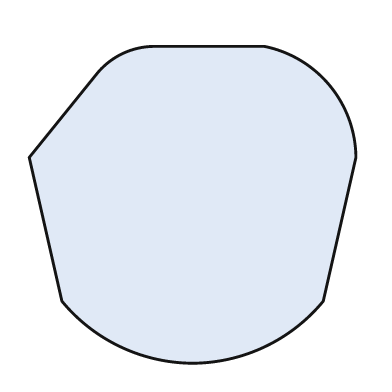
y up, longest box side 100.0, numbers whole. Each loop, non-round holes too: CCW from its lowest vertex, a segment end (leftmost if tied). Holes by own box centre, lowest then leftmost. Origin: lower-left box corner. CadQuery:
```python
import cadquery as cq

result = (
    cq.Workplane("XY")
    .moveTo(50.0, 0.0)
    .threePointArc((72.0, 5.0), (90.0, 19.0))
    .lineTo(100.0, 63.0)
    .threePointArc((92.0, 85.0), (72.0, 97.0))
    .lineTo(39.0, 97.0)
    .threePointArc((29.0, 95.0), (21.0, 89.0))
    .lineTo(0.0, 63.0)
    .lineTo(10.0, 19.0)
    .threePointArc((28.0, 5.0), (50.0, 0.0))
    .close()
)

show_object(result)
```